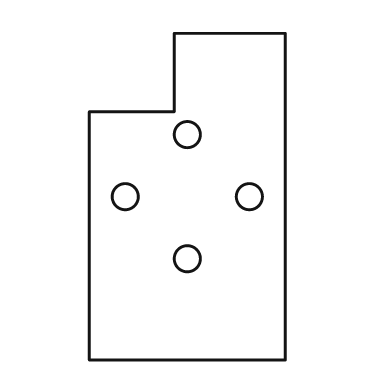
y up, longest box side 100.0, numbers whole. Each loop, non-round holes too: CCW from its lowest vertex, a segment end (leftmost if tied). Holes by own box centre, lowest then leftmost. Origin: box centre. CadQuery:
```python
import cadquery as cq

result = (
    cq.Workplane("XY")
    .moveTo(-30.0, -50.0)
    .lineTo(30.0, -50.0)
    .lineTo(30.0, 50.0)
    .lineTo(-4.0, 50.0)
    .lineTo(-4.0, 26.0)
    .lineTo(-30.0, 26.0)
    .close()
    .moveTo(0.0, -19.0)
    .circle(4.0)
    .moveTo(-19.0, 0.0)
    .circle(4.0)
    .moveTo(19.0, 0.0)
    .circle(4.0)
    .moveTo(0.0, 19.0)
    .circle(4.0)
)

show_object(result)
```